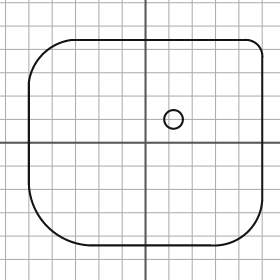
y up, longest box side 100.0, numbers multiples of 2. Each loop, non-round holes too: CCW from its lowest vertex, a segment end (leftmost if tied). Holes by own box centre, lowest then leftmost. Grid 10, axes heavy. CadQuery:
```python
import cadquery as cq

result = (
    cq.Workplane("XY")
    .moveTo(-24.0, -44.0)
    .lineTo(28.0, -44.0)
    .threePointArc((44.0, -38.0), (50.0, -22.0))
    .lineTo(50.0, 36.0)
    .threePointArc((48.0, 42.0), (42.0, 44.0))
    .lineTo(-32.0, 44.0)
    .threePointArc((-44.0, 38.0), (-50.0, 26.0))
    .lineTo(-50.0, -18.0)
    .threePointArc((-42.0, -36.0), (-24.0, -44.0))
    .close()
    .moveTo(12.0, 10.0)
    .circle(4.0)
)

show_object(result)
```